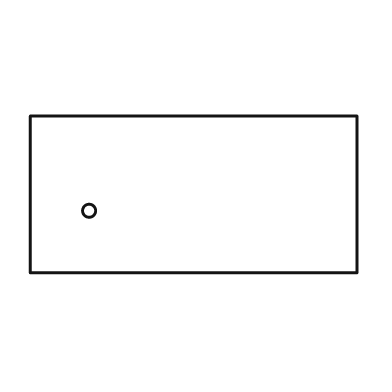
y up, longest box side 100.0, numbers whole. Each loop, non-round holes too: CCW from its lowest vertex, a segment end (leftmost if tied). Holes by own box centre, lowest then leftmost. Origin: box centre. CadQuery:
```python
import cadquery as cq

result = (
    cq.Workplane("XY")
    .moveTo(-50.0, -24.0)
    .lineTo(50.0, -24.0)
    .lineTo(50.0, 24.0)
    .lineTo(-50.0, 24.0)
    .close()
    .moveTo(-32.0, -5.0)
    .circle(2.0)
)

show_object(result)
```